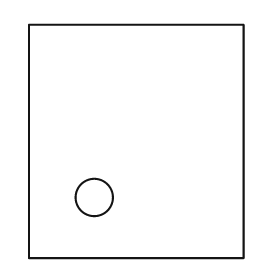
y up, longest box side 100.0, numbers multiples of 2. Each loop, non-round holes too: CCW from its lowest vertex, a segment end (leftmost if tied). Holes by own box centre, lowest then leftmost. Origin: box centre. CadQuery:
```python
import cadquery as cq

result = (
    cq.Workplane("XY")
    .moveTo(-46.0, -50.0)
    .lineTo(46.0, -50.0)
    .lineTo(46.0, 50.0)
    .lineTo(-46.0, 50.0)
    .close()
    .moveTo(-18.0, -24.0)
    .circle(8.0)
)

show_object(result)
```